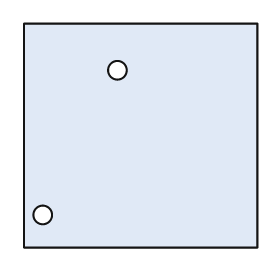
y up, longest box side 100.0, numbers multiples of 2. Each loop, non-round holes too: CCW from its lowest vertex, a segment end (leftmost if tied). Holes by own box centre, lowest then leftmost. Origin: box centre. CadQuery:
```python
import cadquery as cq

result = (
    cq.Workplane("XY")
    .moveTo(-50.0, -48.0)
    .lineTo(50.0, -48.0)
    .lineTo(50.0, 48.0)
    .lineTo(-50.0, 48.0)
    .close()
    .moveTo(-42.0, -34.0)
    .circle(4.0)
    .moveTo(-10.0, 28.0)
    .circle(4.0)
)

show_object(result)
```